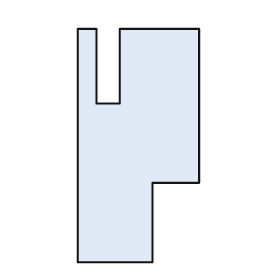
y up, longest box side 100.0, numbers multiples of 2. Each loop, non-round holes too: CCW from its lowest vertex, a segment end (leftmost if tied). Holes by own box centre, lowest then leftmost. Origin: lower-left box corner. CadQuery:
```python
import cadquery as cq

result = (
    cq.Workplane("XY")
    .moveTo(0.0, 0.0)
    .lineTo(32.0, 0.0)
    .lineTo(32.0, 34.0)
    .lineTo(52.0, 34.0)
    .lineTo(52.0, 100.0)
    .lineTo(18.0, 100.0)
    .lineTo(18.0, 68.0)
    .lineTo(8.0, 68.0)
    .lineTo(8.0, 100.0)
    .lineTo(0.0, 100.0)
    .close()
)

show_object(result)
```